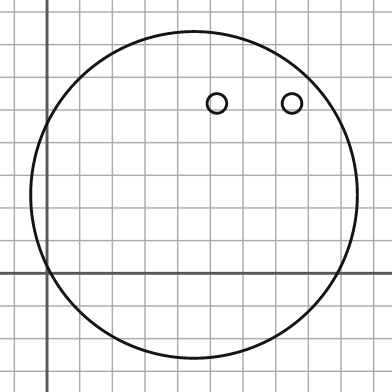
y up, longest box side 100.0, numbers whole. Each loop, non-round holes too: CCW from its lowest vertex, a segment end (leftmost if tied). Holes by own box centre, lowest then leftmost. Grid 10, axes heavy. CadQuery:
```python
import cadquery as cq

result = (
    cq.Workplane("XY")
    .moveTo(45.0, 24.0)
    .circle(50.0)
    .moveTo(52.0, 52.0)
    .circle(3.0)
    .moveTo(75.0, 52.0)
    .circle(3.0)
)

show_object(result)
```